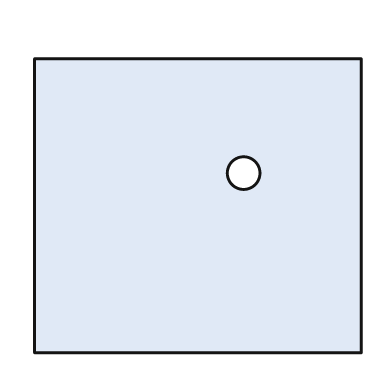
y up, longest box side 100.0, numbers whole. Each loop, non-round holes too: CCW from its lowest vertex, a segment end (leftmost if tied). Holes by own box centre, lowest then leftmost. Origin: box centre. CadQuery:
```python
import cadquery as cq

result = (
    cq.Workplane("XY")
    .moveTo(-50.0, -45.0)
    .lineTo(50.0, -45.0)
    .lineTo(50.0, 45.0)
    .lineTo(-50.0, 45.0)
    .close()
    .moveTo(14.0, 10.0)
    .circle(5.0)
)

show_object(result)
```